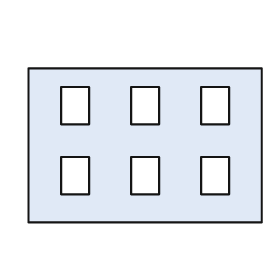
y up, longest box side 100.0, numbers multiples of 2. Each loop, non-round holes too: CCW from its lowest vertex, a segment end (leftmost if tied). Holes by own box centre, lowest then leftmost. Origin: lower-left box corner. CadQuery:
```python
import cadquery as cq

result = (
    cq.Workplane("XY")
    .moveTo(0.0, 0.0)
    .lineTo(100.0, 0.0)
    .lineTo(100.0, 66.0)
    .lineTo(0.0, 66.0)
    .close()
    .moveTo(14.0, 12.0)
    .lineTo(26.0, 12.0)
    .lineTo(26.0, 28.0)
    .lineTo(14.0, 28.0)
    .close()
    .moveTo(44.0, 12.0)
    .lineTo(56.0, 12.0)
    .lineTo(56.0, 28.0)
    .lineTo(44.0, 28.0)
    .close()
    .moveTo(74.0, 12.0)
    .lineTo(86.0, 12.0)
    .lineTo(86.0, 28.0)
    .lineTo(74.0, 28.0)
    .close()
    .moveTo(14.0, 42.0)
    .lineTo(26.0, 42.0)
    .lineTo(26.0, 58.0)
    .lineTo(14.0, 58.0)
    .close()
    .moveTo(44.0, 42.0)
    .lineTo(56.0, 42.0)
    .lineTo(56.0, 58.0)
    .lineTo(44.0, 58.0)
    .close()
    .moveTo(74.0, 42.0)
    .lineTo(86.0, 42.0)
    .lineTo(86.0, 58.0)
    .lineTo(74.0, 58.0)
    .close()
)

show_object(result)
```